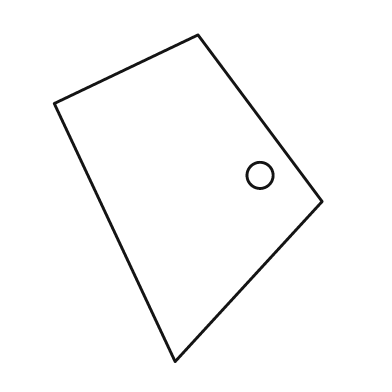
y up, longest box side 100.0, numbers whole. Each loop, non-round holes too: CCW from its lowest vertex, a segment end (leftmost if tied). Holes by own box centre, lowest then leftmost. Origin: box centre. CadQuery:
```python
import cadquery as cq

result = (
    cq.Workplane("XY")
    .moveTo(-4.0, -50.0)
    .lineTo(41.0, -1.0)
    .lineTo(3.0, 50.0)
    .lineTo(-41.0, 29.0)
    .close()
    .moveTo(22.0, 7.0)
    .circle(4.0)
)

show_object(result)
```